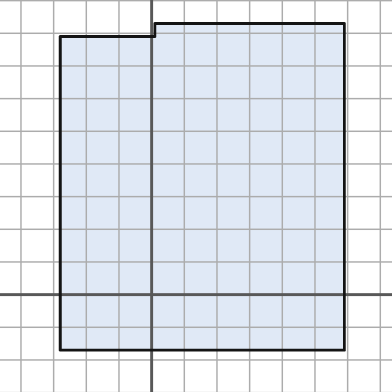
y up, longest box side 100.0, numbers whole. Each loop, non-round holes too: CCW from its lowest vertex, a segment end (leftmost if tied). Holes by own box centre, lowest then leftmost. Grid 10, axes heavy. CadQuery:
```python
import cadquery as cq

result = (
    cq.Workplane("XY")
    .moveTo(-28.0, -17.0)
    .lineTo(59.0, -17.0)
    .lineTo(59.0, 83.0)
    .lineTo(1.0, 83.0)
    .lineTo(1.0, 79.0)
    .lineTo(-28.0, 79.0)
    .close()
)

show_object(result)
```